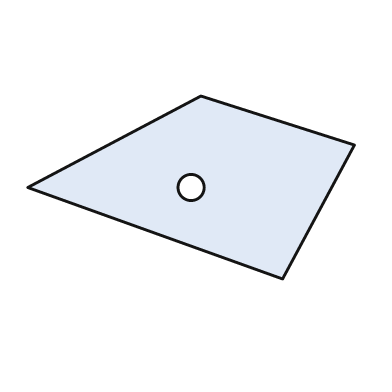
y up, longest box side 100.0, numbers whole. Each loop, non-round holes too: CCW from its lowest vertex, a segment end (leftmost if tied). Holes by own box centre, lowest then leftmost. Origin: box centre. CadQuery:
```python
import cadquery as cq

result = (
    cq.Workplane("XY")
    .moveTo(28.0, -28.0)
    .lineTo(50.0, 13.0)
    .lineTo(3.0, 28.0)
    .lineTo(-50.0, 0.0)
    .close()
    .moveTo(0.0, 0.0)
    .circle(4.0)
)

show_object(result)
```